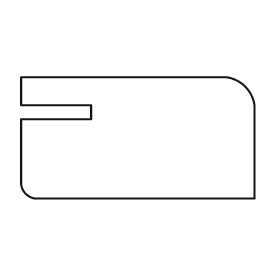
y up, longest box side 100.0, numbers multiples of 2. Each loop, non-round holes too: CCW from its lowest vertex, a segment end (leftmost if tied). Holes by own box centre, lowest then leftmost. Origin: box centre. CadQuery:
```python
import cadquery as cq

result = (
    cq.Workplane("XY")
    .moveTo(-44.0, -26.0)
    .lineTo(50.0, -26.0)
    .lineTo(50.0, 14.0)
    .threePointArc((46.0, 22.0), (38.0, 26.0))
    .lineTo(-50.0, 26.0)
    .lineTo(-50.0, 14.0)
    .lineTo(-20.0, 14.0)
    .lineTo(-20.0, 8.0)
    .lineTo(-50.0, 8.0)
    .lineTo(-50.0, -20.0)
    .threePointArc((-48.0, -24.0), (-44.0, -26.0))
    .close()
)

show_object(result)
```